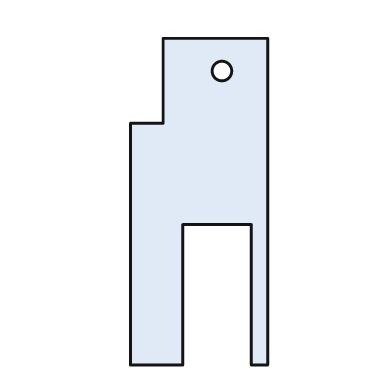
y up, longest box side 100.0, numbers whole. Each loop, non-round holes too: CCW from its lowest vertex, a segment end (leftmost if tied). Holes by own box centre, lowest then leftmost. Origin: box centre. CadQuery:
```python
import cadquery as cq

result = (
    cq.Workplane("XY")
    .moveTo(-21.0, -50.0)
    .lineTo(-5.0, -50.0)
    .lineTo(-5.0, -7.0)
    .lineTo(16.0, -7.0)
    .lineTo(16.0, -50.0)
    .lineTo(21.0, -50.0)
    .lineTo(21.0, 50.0)
    .lineTo(-11.0, 50.0)
    .lineTo(-11.0, 24.0)
    .lineTo(-21.0, 24.0)
    .close()
    .moveTo(7.0, 40.0)
    .circle(3.0)
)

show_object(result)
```